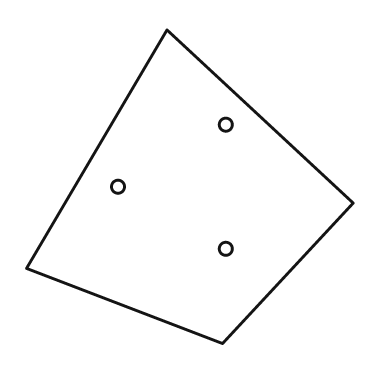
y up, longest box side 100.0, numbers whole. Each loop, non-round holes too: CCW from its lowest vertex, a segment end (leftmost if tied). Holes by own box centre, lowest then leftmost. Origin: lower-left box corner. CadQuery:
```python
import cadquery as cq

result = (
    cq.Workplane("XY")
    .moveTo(60.0, 0.0)
    .lineTo(100.0, 43.0)
    .lineTo(43.0, 96.0)
    .lineTo(0.0, 23.0)
    .close()
    .moveTo(61.0, 29.0)
    .circle(2.0)
    .moveTo(28.0, 48.0)
    .circle(2.0)
    .moveTo(61.0, 67.0)
    .circle(2.0)
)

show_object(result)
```